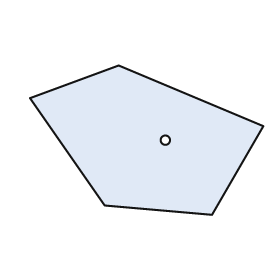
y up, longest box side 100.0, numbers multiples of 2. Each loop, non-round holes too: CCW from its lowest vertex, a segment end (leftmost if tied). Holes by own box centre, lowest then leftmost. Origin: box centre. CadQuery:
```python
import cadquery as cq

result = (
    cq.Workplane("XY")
    .moveTo(28.0, -32.0)
    .lineTo(50.0, 6.0)
    .lineTo(-12.0, 32.0)
    .lineTo(-50.0, 18.0)
    .lineTo(-18.0, -28.0)
    .close()
    .moveTo(8.0, 0.0)
    .circle(2.0)
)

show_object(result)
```